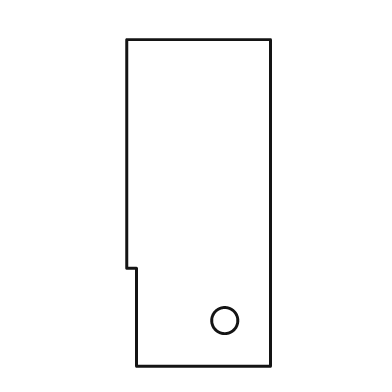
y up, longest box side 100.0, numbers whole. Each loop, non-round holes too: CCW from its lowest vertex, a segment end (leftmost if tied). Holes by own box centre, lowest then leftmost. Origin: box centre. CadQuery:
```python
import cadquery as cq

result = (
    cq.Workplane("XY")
    .moveTo(-19.0, -50.0)
    .lineTo(22.0, -50.0)
    .lineTo(22.0, 50.0)
    .lineTo(-22.0, 50.0)
    .lineTo(-22.0, -20.0)
    .lineTo(-19.0, -20.0)
    .close()
    .moveTo(8.0, -36.0)
    .circle(4.0)
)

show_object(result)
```